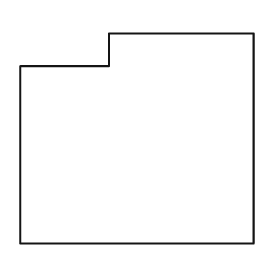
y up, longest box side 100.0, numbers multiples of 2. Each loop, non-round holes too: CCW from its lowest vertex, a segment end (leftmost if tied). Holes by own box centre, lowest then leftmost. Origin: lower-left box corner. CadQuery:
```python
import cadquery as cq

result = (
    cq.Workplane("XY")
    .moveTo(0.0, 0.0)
    .lineTo(100.0, 0.0)
    .lineTo(100.0, 90.0)
    .lineTo(38.0, 90.0)
    .lineTo(38.0, 76.0)
    .lineTo(0.0, 76.0)
    .close()
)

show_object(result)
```